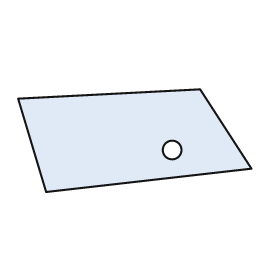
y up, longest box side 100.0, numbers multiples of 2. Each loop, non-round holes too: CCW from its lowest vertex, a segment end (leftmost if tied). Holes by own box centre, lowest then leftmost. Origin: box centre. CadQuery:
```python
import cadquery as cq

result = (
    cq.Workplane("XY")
    .moveTo(-38.0, -22.0)
    .lineTo(50.0, -12.0)
    .lineTo(28.0, 22.0)
    .lineTo(-50.0, 18.0)
    .close()
    .moveTo(16.0, -4.0)
    .circle(4.0)
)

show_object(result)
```